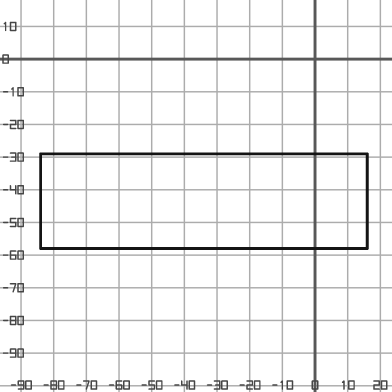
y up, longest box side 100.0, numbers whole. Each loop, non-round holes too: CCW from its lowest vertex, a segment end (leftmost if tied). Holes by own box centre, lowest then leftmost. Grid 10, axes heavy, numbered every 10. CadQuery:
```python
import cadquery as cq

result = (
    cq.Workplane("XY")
    .moveTo(-84.0, -58.0)
    .lineTo(16.0, -58.0)
    .lineTo(16.0, -29.0)
    .lineTo(-84.0, -29.0)
    .close()
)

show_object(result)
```